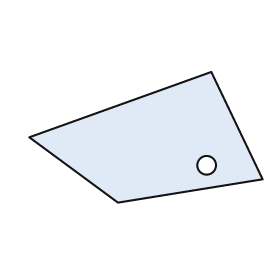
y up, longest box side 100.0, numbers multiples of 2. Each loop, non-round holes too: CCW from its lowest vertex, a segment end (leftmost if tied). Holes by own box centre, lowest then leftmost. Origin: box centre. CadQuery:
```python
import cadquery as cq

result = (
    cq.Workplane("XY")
    .moveTo(-12.0, -28.0)
    .lineTo(50.0, -18.0)
    .lineTo(28.0, 28.0)
    .lineTo(-50.0, 0.0)
    .close()
    .moveTo(26.0, -12.0)
    .circle(4.0)
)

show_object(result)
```